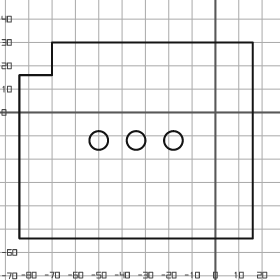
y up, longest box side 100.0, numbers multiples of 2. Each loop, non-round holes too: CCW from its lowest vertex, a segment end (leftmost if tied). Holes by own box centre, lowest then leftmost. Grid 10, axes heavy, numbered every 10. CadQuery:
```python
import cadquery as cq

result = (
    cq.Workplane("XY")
    .moveTo(-84.0, -54.0)
    .lineTo(16.0, -54.0)
    .lineTo(16.0, 30.0)
    .lineTo(-70.0, 30.0)
    .lineTo(-70.0, 16.0)
    .lineTo(-84.0, 16.0)
    .close()
    .moveTo(-50.0, -12.0)
    .circle(4.0)
    .moveTo(-34.0, -12.0)
    .circle(4.0)
    .moveTo(-18.0, -12.0)
    .circle(4.0)
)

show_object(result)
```